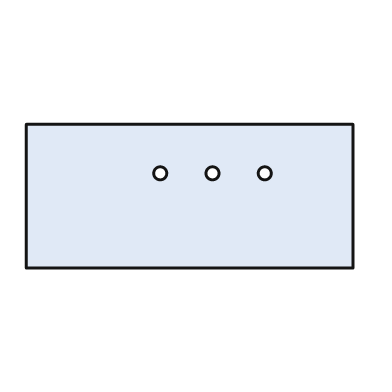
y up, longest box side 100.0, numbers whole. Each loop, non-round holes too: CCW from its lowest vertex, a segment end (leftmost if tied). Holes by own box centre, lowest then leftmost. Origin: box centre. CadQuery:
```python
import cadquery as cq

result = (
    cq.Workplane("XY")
    .moveTo(-50.0, -22.0)
    .lineTo(50.0, -22.0)
    .lineTo(50.0, 22.0)
    .lineTo(-50.0, 22.0)
    .close()
    .moveTo(-9.0, 7.0)
    .circle(2.0)
    .moveTo(7.0, 7.0)
    .circle(2.0)
    .moveTo(23.0, 7.0)
    .circle(2.0)
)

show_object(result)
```